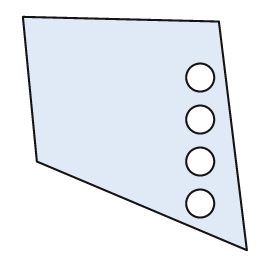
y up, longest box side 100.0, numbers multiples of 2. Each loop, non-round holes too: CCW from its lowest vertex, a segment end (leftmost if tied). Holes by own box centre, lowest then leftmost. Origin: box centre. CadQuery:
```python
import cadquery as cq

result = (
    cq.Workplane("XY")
    .moveTo(48.0, -50.0)
    .lineTo(36.0, 48.0)
    .lineTo(-48.0, 50.0)
    .lineTo(-42.0, -12.0)
    .close()
    .moveTo(28.0, -30.0)
    .circle(6.0)
    .moveTo(28.0, -12.0)
    .circle(6.0)
    .moveTo(28.0, 6.0)
    .circle(6.0)
    .moveTo(28.0, 24.0)
    .circle(6.0)
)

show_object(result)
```